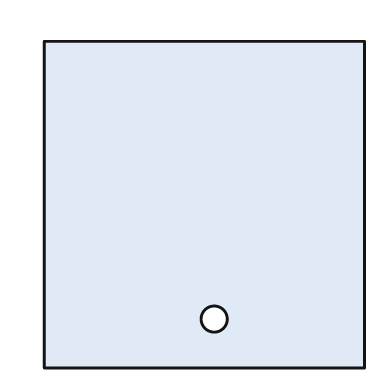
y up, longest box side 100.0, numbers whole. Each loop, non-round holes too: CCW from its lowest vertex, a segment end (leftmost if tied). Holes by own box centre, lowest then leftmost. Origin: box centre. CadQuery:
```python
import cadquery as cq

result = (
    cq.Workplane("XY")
    .moveTo(-49.0, -50.0)
    .lineTo(49.0, -50.0)
    .lineTo(49.0, 50.0)
    .lineTo(-49.0, 50.0)
    .close()
    .moveTo(3.0, -35.0)
    .circle(4.0)
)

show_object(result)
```